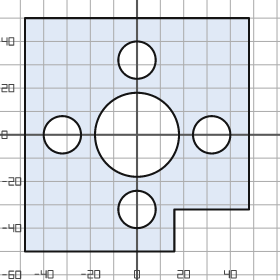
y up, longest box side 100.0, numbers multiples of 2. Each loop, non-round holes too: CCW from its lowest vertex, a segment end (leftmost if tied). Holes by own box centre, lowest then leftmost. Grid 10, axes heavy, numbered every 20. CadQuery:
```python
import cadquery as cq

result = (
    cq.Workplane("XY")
    .moveTo(-48.0, -50.0)
    .lineTo(16.0, -50.0)
    .lineTo(16.0, -32.0)
    .lineTo(48.0, -32.0)
    .lineTo(48.0, 50.0)
    .lineTo(-48.0, 50.0)
    .close()
    .moveTo(0.0, -32.0)
    .circle(8.0)
    .moveTo(-32.0, 0.0)
    .circle(8.0)
    .moveTo(0.0, 0.0)
    .circle(18.0)
    .moveTo(32.0, 0.0)
    .circle(8.0)
    .moveTo(0.0, 32.0)
    .circle(8.0)
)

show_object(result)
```